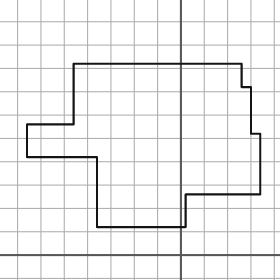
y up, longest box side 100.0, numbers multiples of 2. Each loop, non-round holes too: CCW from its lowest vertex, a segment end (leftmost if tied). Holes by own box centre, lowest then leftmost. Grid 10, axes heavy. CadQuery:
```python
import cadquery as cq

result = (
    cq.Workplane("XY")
    .moveTo(-36.0, 12.0)
    .lineTo(2.0, 12.0)
    .lineTo(2.0, 26.0)
    .lineTo(34.0, 26.0)
    .lineTo(34.0, 52.0)
    .lineTo(30.0, 52.0)
    .lineTo(30.0, 72.0)
    .lineTo(26.0, 72.0)
    .lineTo(26.0, 82.0)
    .lineTo(-46.0, 82.0)
    .lineTo(-46.0, 56.0)
    .lineTo(-66.0, 56.0)
    .lineTo(-66.0, 42.0)
    .lineTo(-36.0, 42.0)
    .close()
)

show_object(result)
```